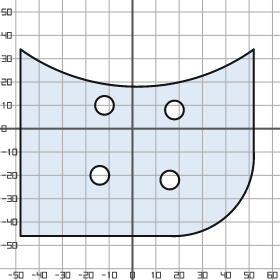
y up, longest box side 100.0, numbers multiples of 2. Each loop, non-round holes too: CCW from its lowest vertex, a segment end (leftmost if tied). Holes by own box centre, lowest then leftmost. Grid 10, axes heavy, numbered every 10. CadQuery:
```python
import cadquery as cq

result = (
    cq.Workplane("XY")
    .moveTo(-48.0, -46.0)
    .lineTo(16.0, -46.0)
    .threePointArc((42.0, -36.0), (52.0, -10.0))
    .lineTo(52.0, 34.0)
    .threePointArc((2.0, 18.0), (-48.0, 34.0))
    .close()
    .moveTo(16.0, -22.0)
    .circle(4.0)
    .moveTo(-14.0, -20.0)
    .circle(4.0)
    .moveTo(18.0, 8.0)
    .circle(4.0)
    .moveTo(-12.0, 10.0)
    .circle(4.0)
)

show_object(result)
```